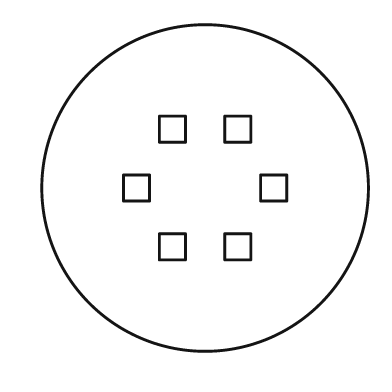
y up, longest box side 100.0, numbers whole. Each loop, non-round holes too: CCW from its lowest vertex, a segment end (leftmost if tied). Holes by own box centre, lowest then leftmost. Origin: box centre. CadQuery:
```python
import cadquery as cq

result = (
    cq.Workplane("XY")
    .moveTo(0.0, 0.0)
    .circle(50.0)
    .moveTo(-14.0, -22.0)
    .lineTo(-6.0, -22.0)
    .lineTo(-6.0, -14.0)
    .lineTo(-14.0, -14.0)
    .close()
    .moveTo(6.0, -22.0)
    .lineTo(14.0, -22.0)
    .lineTo(14.0, -14.0)
    .lineTo(6.0, -14.0)
    .close()
    .moveTo(-25.0, -4.0)
    .lineTo(-17.0, -4.0)
    .lineTo(-17.0, 4.0)
    .lineTo(-25.0, 4.0)
    .close()
    .moveTo(17.0, -4.0)
    .lineTo(25.0, -4.0)
    .lineTo(25.0, 4.0)
    .lineTo(17.0, 4.0)
    .close()
    .moveTo(-14.0, 14.0)
    .lineTo(-6.0, 14.0)
    .lineTo(-6.0, 22.0)
    .lineTo(-14.0, 22.0)
    .close()
    .moveTo(6.0, 14.0)
    .lineTo(14.0, 14.0)
    .lineTo(14.0, 22.0)
    .lineTo(6.0, 22.0)
    .close()
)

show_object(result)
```